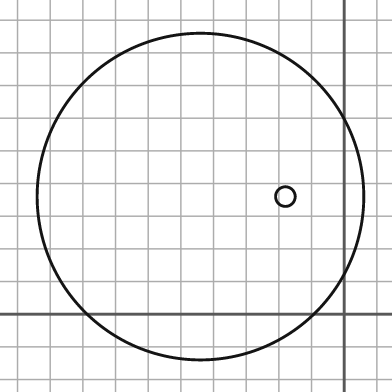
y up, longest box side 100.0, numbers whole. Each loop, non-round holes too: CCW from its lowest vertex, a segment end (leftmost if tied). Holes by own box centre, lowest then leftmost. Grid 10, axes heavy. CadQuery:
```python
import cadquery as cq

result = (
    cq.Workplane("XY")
    .moveTo(-44.0, 36.0)
    .circle(50.0)
    .moveTo(-18.0, 36.0)
    .circle(3.0)
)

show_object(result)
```